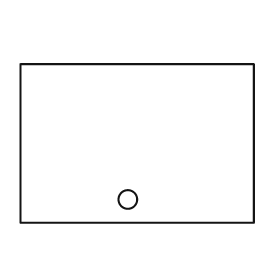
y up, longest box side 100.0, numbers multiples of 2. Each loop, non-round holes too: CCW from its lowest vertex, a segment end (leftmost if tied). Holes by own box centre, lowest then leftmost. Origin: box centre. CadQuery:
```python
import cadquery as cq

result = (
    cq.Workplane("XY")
    .moveTo(-50.0, -34.0)
    .lineTo(50.0, -34.0)
    .lineTo(50.0, 34.0)
    .lineTo(-50.0, 34.0)
    .close()
    .moveTo(-4.0, -24.0)
    .circle(4.0)
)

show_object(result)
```